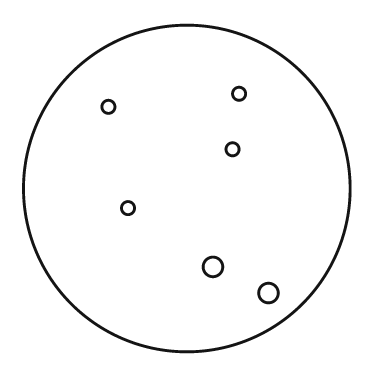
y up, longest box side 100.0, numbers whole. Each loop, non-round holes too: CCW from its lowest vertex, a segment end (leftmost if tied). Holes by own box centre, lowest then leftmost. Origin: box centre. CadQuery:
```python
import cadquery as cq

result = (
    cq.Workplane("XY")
    .moveTo(0.0, 0.0)
    .circle(50.0)
    .moveTo(25.0, -32.0)
    .circle(3.0)
    .moveTo(8.0, -24.0)
    .circle(3.0)
    .moveTo(-18.0, -6.0)
    .circle(2.0)
    .moveTo(14.0, 12.0)
    .circle(2.0)
    .moveTo(-24.0, 25.0)
    .circle(2.0)
    .moveTo(16.0, 29.0)
    .circle(2.0)
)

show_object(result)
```